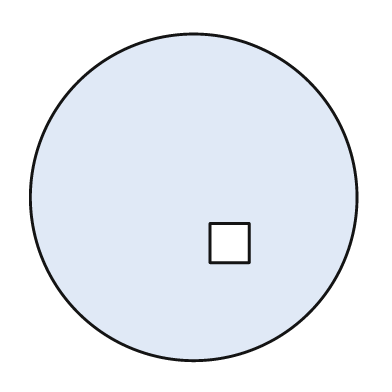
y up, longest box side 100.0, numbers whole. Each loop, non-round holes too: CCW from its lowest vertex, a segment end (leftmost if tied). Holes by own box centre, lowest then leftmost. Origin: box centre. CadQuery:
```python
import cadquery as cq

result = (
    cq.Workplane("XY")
    .moveTo(0.0, 0.0)
    .circle(50.0)
    .moveTo(5.0, -20.0)
    .lineTo(17.0, -20.0)
    .lineTo(17.0, -8.0)
    .lineTo(5.0, -8.0)
    .close()
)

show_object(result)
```